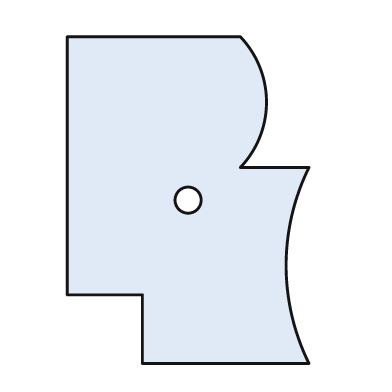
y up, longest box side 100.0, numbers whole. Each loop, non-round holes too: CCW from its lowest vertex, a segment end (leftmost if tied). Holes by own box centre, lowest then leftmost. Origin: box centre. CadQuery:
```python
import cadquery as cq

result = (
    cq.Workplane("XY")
    .moveTo(-14.0, -50.0)
    .lineTo(37.0, -50.0)
    .threePointArc((30.0, -20.0), (37.0, 10.0))
    .lineTo(16.0, 10.0)
    .threePointArc((24.0, 30.0), (16.0, 50.0))
    .lineTo(-37.0, 50.0)
    .lineTo(-37.0, -29.0)
    .lineTo(-14.0, -29.0)
    .close()
    .moveTo(0.0, 0.0)
    .circle(4.0)
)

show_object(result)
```